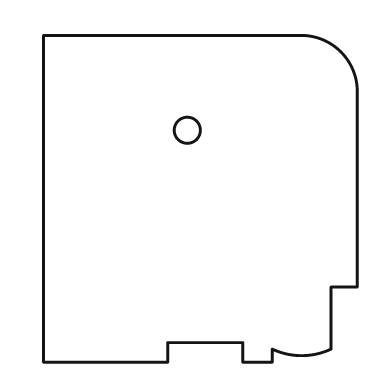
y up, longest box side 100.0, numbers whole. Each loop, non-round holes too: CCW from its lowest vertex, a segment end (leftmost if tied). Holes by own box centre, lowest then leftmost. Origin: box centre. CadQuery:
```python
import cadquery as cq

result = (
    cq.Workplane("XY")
    .moveTo(-48.0, -50.0)
    .lineTo(-10.0, -50.0)
    .lineTo(-10.0, -44.0)
    .lineTo(13.0, -44.0)
    .lineTo(13.0, -50.0)
    .lineTo(22.0, -50.0)
    .lineTo(22.0, -46.0)
    .threePointArc((31.0, -48.0), (40.0, -46.0))
    .lineTo(40.0, -27.0)
    .lineTo(48.0, -27.0)
    .lineTo(48.0, 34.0)
    .threePointArc((43.0, 45.0), (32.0, 50.0))
    .lineTo(-48.0, 50.0)
    .close()
    .moveTo(-4.0, 21.0)
    .circle(4.0)
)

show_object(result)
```